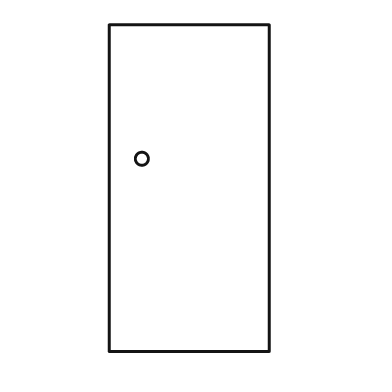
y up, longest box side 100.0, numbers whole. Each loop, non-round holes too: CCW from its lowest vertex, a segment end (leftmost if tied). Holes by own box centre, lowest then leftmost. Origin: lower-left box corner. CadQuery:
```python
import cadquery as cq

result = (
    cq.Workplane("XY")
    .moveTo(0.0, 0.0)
    .lineTo(49.0, 0.0)
    .lineTo(49.0, 100.0)
    .lineTo(0.0, 100.0)
    .close()
    .moveTo(10.0, 59.0)
    .circle(2.0)
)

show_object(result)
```